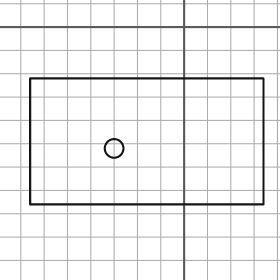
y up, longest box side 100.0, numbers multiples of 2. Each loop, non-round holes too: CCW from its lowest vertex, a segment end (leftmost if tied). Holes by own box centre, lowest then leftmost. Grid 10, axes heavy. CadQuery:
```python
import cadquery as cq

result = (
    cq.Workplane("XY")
    .moveTo(-66.0, -76.0)
    .lineTo(34.0, -76.0)
    .lineTo(34.0, -22.0)
    .lineTo(-66.0, -22.0)
    .close()
    .moveTo(-30.0, -52.0)
    .circle(4.0)
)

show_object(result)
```